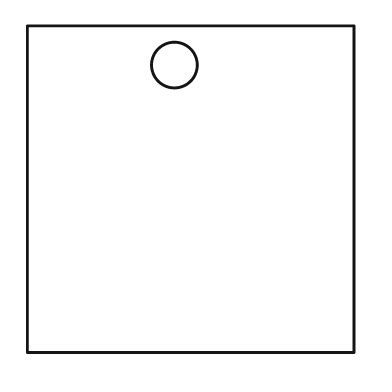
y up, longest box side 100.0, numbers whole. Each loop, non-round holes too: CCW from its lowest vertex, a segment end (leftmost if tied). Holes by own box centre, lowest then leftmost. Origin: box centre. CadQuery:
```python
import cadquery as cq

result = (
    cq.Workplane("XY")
    .moveTo(-50.0, -50.0)
    .lineTo(50.0, -50.0)
    .lineTo(50.0, 50.0)
    .lineTo(-50.0, 50.0)
    .close()
    .moveTo(-5.0, 38.0)
    .circle(7.0)
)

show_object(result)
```